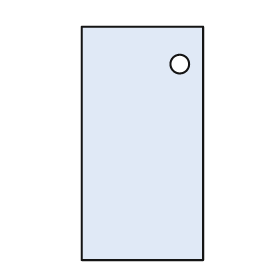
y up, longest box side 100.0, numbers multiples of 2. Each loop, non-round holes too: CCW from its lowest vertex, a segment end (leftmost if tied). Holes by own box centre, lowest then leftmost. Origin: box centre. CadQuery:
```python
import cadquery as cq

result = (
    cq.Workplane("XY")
    .moveTo(-26.0, -50.0)
    .lineTo(26.0, -50.0)
    .lineTo(26.0, 50.0)
    .lineTo(-26.0, 50.0)
    .close()
    .moveTo(16.0, 34.0)
    .circle(4.0)
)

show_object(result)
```